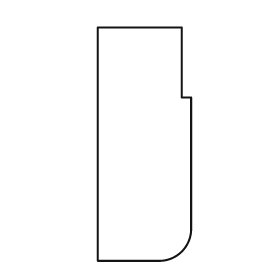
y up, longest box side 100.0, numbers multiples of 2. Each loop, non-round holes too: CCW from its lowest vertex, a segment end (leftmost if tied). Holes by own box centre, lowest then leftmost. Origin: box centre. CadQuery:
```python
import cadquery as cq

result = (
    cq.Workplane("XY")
    .moveTo(-20.0, -50.0)
    .lineTo(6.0, -50.0)
    .threePointArc((16.0, -46.0), (20.0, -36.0))
    .lineTo(20.0, 20.0)
    .lineTo(16.0, 20.0)
    .lineTo(16.0, 50.0)
    .lineTo(-20.0, 50.0)
    .close()
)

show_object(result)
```